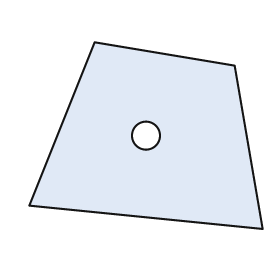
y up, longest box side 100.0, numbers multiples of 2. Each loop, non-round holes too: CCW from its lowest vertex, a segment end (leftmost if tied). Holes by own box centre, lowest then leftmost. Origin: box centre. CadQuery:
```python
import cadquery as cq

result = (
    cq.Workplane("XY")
    .moveTo(50.0, -40.0)
    .lineTo(38.0, 30.0)
    .lineTo(-22.0, 40.0)
    .lineTo(-50.0, -30.0)
    .close()
    .moveTo(0.0, 0.0)
    .circle(6.0)
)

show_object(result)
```